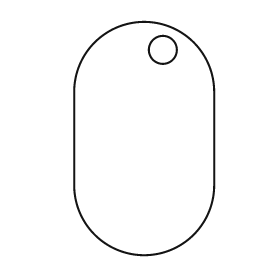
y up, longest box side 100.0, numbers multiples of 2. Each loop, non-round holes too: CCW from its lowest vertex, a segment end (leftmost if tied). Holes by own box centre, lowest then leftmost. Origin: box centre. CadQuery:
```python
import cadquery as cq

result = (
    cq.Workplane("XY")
    .moveTo(-30.0, -20.0)
    .threePointArc((0.0, -50.0), (30.0, -20.0))
    .lineTo(30.0, 20.0)
    .threePointArc((0.0, 50.0), (-30.0, 20.0))
    .close()
    .moveTo(8.0, 38.0)
    .circle(6.0)
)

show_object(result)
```